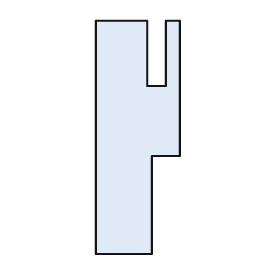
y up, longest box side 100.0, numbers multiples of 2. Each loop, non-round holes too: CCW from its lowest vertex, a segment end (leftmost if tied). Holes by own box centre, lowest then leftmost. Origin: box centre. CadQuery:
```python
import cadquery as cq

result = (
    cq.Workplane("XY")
    .moveTo(-18.0, -50.0)
    .lineTo(6.0, -50.0)
    .lineTo(6.0, -8.0)
    .lineTo(18.0, -8.0)
    .lineTo(18.0, 50.0)
    .lineTo(12.0, 50.0)
    .lineTo(12.0, 22.0)
    .lineTo(4.0, 22.0)
    .lineTo(4.0, 50.0)
    .lineTo(-18.0, 50.0)
    .close()
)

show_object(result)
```